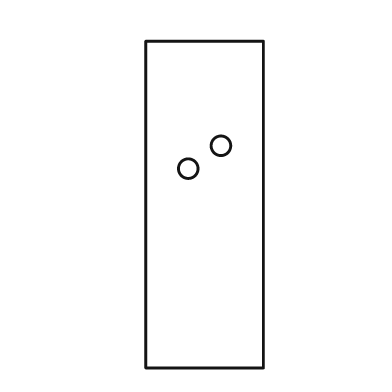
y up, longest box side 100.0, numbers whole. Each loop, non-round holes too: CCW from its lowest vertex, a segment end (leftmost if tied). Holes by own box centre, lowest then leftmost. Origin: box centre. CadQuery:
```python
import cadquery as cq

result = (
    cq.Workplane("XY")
    .moveTo(-18.0, -50.0)
    .lineTo(18.0, -50.0)
    .lineTo(18.0, 50.0)
    .lineTo(-18.0, 50.0)
    .close()
    .moveTo(-5.0, 11.0)
    .circle(3.0)
    .moveTo(5.0, 18.0)
    .circle(3.0)
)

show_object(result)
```